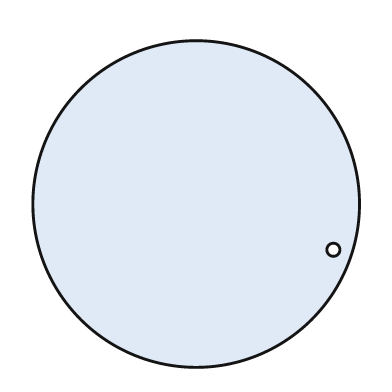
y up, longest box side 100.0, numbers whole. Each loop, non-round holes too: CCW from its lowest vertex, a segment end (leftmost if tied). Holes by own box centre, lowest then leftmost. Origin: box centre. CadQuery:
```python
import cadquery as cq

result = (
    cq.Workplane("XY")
    .moveTo(0.0, 0.0)
    .circle(50.0)
    .moveTo(42.0, -14.0)
    .circle(2.0)
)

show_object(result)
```